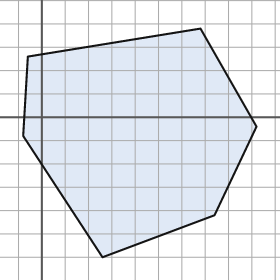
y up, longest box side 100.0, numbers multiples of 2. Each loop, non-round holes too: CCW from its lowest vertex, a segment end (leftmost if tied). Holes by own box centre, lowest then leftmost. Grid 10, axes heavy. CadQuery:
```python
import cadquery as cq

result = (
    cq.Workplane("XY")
    .moveTo(26.0, -60.0)
    .lineTo(74.0, -42.0)
    .lineTo(92.0, -4.0)
    .lineTo(68.0, 38.0)
    .lineTo(-6.0, 26.0)
    .lineTo(-8.0, -8.0)
    .close()
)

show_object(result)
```